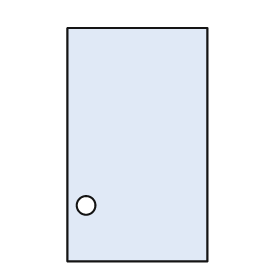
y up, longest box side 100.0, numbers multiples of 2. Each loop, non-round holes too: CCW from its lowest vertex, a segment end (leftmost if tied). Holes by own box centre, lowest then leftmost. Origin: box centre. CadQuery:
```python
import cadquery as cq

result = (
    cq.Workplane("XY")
    .moveTo(-30.0, -50.0)
    .lineTo(30.0, -50.0)
    .lineTo(30.0, 50.0)
    .lineTo(-30.0, 50.0)
    .close()
    .moveTo(-22.0, -26.0)
    .circle(4.0)
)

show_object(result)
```